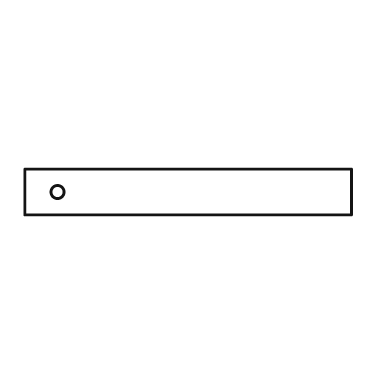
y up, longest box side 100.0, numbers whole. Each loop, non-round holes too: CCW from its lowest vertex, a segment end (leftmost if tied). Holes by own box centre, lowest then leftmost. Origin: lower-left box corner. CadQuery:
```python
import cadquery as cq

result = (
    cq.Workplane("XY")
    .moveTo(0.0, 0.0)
    .lineTo(100.0, 0.0)
    .lineTo(100.0, 14.0)
    .lineTo(0.0, 14.0)
    .close()
    .moveTo(10.0, 7.0)
    .circle(2.0)
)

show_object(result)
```